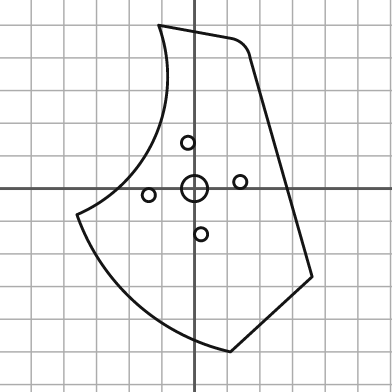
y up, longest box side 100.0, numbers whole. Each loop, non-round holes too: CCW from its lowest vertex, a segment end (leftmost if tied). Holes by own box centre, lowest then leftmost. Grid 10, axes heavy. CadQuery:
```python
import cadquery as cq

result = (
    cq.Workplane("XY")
    .moveTo(11.0, -50.0)
    .lineTo(36.0, -27.0)
    .lineTo(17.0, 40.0)
    .threePointArc((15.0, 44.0), (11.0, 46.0))
    .lineTo(-11.0, 50.0)
    .threePointArc((-12.0, 16.0), (-36.0, -8.0))
    .threePointArc((-18.0, -35.0), (11.0, -50.0))
    .close()
    .moveTo(2.0, -14.0)
    .circle(2.0)
    .moveTo(-14.0, -2.0)
    .circle(2.0)
    .moveTo(0.0, 0.0)
    .circle(4.0)
    .moveTo(14.0, 2.0)
    .circle(2.0)
    .moveTo(-2.0, 14.0)
    .circle(2.0)
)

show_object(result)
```